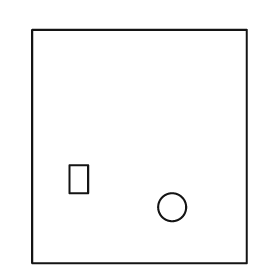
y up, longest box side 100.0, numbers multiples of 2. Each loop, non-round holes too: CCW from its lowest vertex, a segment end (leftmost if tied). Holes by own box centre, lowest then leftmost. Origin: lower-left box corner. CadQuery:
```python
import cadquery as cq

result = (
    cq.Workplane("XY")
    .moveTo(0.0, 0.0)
    .lineTo(92.0, 0.0)
    .lineTo(92.0, 100.0)
    .lineTo(0.0, 100.0)
    .close()
    .moveTo(60.0, 24.0)
    .circle(6.0)
    .moveTo(16.0, 30.0)
    .lineTo(24.0, 30.0)
    .lineTo(24.0, 42.0)
    .lineTo(16.0, 42.0)
    .close()
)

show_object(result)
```